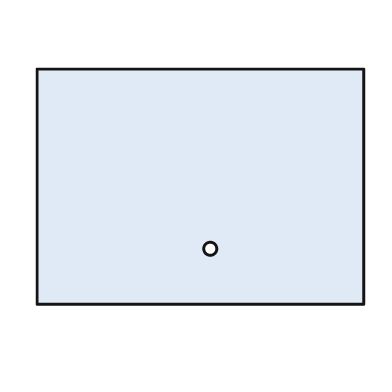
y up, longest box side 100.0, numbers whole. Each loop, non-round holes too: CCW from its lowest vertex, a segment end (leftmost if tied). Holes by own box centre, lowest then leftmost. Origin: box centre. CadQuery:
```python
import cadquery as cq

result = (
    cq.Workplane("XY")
    .moveTo(-50.0, -36.0)
    .lineTo(50.0, -36.0)
    .lineTo(50.0, 36.0)
    .lineTo(-50.0, 36.0)
    .close()
    .moveTo(3.0, -19.0)
    .circle(2.0)
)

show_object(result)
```